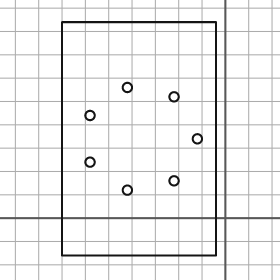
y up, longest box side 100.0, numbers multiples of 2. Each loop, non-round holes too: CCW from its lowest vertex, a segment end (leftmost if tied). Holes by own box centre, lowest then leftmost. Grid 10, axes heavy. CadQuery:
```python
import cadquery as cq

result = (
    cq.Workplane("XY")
    .moveTo(-70.0, -16.0)
    .lineTo(-4.0, -16.0)
    .lineTo(-4.0, 84.0)
    .lineTo(-70.0, 84.0)
    .close()
    .moveTo(-42.0, 12.0)
    .circle(2.0)
    .moveTo(-22.0, 16.0)
    .circle(2.0)
    .moveTo(-58.0, 24.0)
    .circle(2.0)
    .moveTo(-12.0, 34.0)
    .circle(2.0)
    .moveTo(-58.0, 44.0)
    .circle(2.0)
    .moveTo(-22.0, 52.0)
    .circle(2.0)
    .moveTo(-42.0, 56.0)
    .circle(2.0)
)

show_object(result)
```